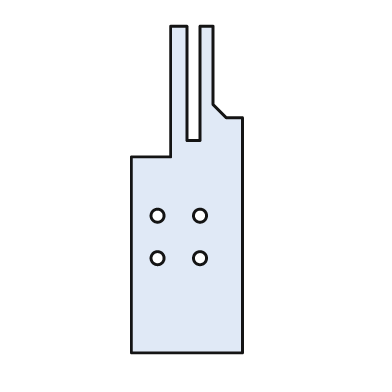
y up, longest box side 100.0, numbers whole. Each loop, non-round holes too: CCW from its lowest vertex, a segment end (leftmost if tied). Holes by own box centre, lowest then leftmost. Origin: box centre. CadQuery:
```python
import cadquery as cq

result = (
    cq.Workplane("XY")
    .moveTo(-17.0, -50.0)
    .lineTo(17.0, -50.0)
    .lineTo(17.0, 22.0)
    .lineTo(12.0, 22.0)
    .lineTo(8.0, 26.0)
    .lineTo(8.0, 50.0)
    .lineTo(4.0, 50.0)
    .lineTo(4.0, 15.0)
    .lineTo(0.0, 15.0)
    .lineTo(0.0, 50.0)
    .lineTo(-5.0, 50.0)
    .lineTo(-5.0, 10.0)
    .lineTo(-17.0, 10.0)
    .close()
    .moveTo(-9.0, -21.0)
    .circle(2.0)
    .moveTo(4.0, -21.0)
    .circle(2.0)
    .moveTo(-9.0, -8.0)
    .circle(2.0)
    .moveTo(4.0, -8.0)
    .circle(2.0)
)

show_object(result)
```